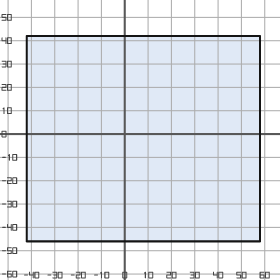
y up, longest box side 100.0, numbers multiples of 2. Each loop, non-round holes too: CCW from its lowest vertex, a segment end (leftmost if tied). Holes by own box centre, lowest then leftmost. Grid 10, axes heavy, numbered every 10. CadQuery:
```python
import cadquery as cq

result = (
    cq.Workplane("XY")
    .moveTo(-42.0, -46.0)
    .lineTo(58.0, -46.0)
    .lineTo(58.0, 42.0)
    .lineTo(-42.0, 42.0)
    .close()
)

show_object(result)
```